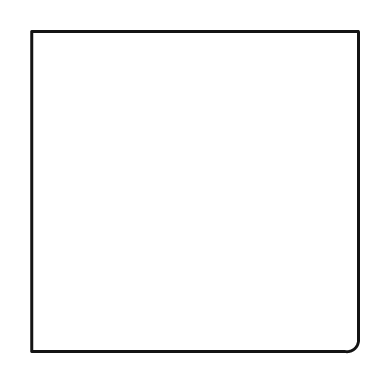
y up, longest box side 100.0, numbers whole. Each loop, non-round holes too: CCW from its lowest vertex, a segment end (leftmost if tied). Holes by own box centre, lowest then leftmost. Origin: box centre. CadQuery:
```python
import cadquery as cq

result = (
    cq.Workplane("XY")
    .moveTo(-50.0, -49.0)
    .lineTo(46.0, -49.0)
    .threePointArc((49.0, -48.0), (50.0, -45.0))
    .lineTo(50.0, 49.0)
    .lineTo(-50.0, 49.0)
    .close()
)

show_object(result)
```